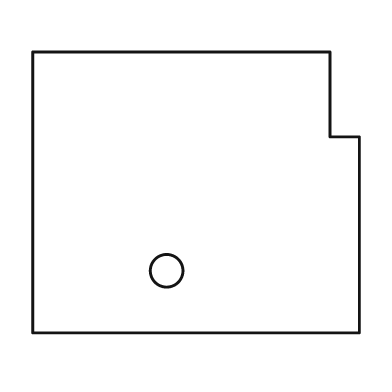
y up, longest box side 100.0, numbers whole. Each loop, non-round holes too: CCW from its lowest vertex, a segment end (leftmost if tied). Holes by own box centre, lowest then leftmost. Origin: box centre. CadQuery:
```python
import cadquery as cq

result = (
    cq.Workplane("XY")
    .moveTo(-50.0, -43.0)
    .lineTo(50.0, -43.0)
    .lineTo(50.0, 17.0)
    .lineTo(41.0, 17.0)
    .lineTo(41.0, 43.0)
    .lineTo(-50.0, 43.0)
    .close()
    .moveTo(-9.0, -24.0)
    .circle(5.0)
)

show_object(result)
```